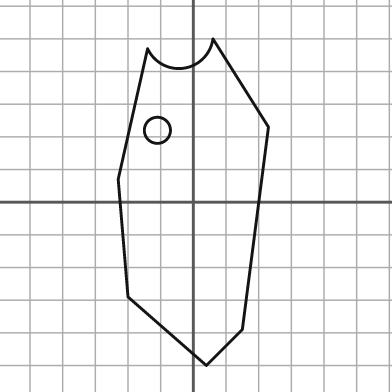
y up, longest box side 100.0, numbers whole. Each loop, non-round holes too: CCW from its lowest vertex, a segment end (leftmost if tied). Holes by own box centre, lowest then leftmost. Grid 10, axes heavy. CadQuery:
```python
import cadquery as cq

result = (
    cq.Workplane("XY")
    .moveTo(4.0, -50.0)
    .lineTo(15.0, -39.0)
    .lineTo(23.0, 23.0)
    .lineTo(6.0, 50.0)
    .threePointArc((-3.0, 41.0), (-14.0, 47.0))
    .lineTo(-23.0, 7.0)
    .lineTo(-20.0, -29.0)
    .close()
    .moveTo(-11.0, 22.0)
    .circle(4.0)
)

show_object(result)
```